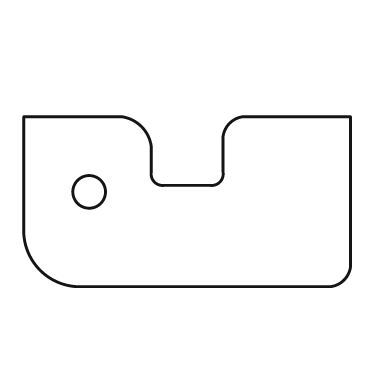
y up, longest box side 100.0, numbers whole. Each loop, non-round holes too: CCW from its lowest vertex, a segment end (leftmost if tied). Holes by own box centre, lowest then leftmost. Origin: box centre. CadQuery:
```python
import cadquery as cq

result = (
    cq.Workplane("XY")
    .moveTo(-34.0, -26.0)
    .lineTo(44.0, -26.0)
    .threePointArc((48.0, -24.0), (50.0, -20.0))
    .lineTo(50.0, 26.0)
    .lineTo(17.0, 26.0)
    .threePointArc((13.0, 24.0), (11.0, 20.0))
    .lineTo(11.0, 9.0)
    .threePointArc((10.0, 6.0), (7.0, 5.0))
    .lineTo(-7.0, 5.0)
    .threePointArc((-10.0, 6.0), (-11.0, 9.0))
    .lineTo(-11.0, 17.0)
    .threePointArc((-14.0, 23.0), (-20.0, 26.0))
    .lineTo(-50.0, 26.0)
    .lineTo(-50.0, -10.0)
    .threePointArc((-45.0, -21.0), (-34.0, -26.0))
    .close()
    .moveTo(-30.0, 3.0)
    .circle(5.0)
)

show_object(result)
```